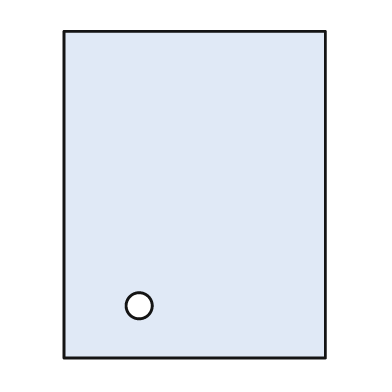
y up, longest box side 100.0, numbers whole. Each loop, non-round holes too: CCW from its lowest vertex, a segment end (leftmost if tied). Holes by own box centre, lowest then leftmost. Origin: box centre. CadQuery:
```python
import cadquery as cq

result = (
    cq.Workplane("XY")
    .moveTo(-40.0, -50.0)
    .lineTo(40.0, -50.0)
    .lineTo(40.0, 50.0)
    .lineTo(-40.0, 50.0)
    .close()
    .moveTo(-17.0, -34.0)
    .circle(4.0)
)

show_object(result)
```